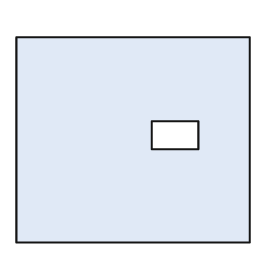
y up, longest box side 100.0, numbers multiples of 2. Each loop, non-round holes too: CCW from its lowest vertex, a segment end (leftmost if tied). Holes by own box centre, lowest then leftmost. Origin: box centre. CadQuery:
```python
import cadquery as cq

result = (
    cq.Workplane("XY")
    .moveTo(-50.0, -44.0)
    .lineTo(50.0, -44.0)
    .lineTo(50.0, 44.0)
    .lineTo(-50.0, 44.0)
    .close()
    .moveTo(8.0, -4.0)
    .lineTo(28.0, -4.0)
    .lineTo(28.0, 8.0)
    .lineTo(8.0, 8.0)
    .close()
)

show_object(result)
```